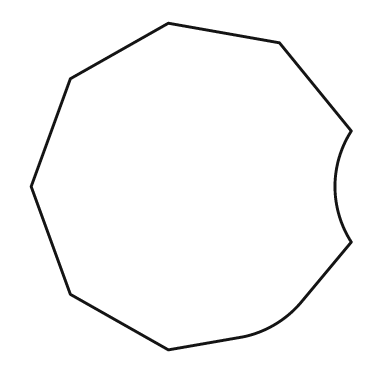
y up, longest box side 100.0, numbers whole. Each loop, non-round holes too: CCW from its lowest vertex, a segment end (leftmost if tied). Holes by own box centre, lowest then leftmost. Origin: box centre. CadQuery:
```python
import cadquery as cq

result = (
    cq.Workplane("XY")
    .moveTo(-7.0, -50.0)
    .lineTo(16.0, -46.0)
    .threePointArc((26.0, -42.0), (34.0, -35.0))
    .lineTo(49.0, -17.0)
    .threePointArc((44.0, 0.0), (49.0, 17.0))
    .lineTo(27.0, 44.0)
    .lineTo(-7.0, 50.0)
    .lineTo(-37.0, 33.0)
    .lineTo(-49.0, 0.0)
    .lineTo(-37.0, -33.0)
    .close()
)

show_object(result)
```